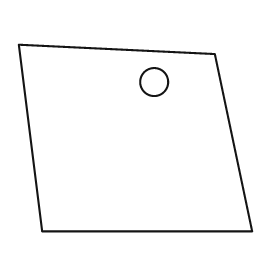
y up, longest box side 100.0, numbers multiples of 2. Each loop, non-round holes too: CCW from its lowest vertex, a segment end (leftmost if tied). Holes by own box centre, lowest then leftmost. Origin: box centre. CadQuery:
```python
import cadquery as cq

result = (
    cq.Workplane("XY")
    .moveTo(-40.0, -40.0)
    .lineTo(50.0, -40.0)
    .lineTo(34.0, 36.0)
    .lineTo(-50.0, 40.0)
    .close()
    .moveTo(8.0, 24.0)
    .circle(6.0)
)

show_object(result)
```